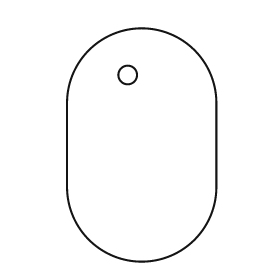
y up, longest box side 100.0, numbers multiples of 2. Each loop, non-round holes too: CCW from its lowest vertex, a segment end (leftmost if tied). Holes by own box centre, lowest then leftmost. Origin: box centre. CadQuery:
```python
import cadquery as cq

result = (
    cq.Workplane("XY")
    .moveTo(-32.0, -18.0)
    .threePointArc((0.0, -50.0), (32.0, -18.0))
    .lineTo(32.0, 18.0)
    .threePointArc((0.0, 50.0), (-32.0, 18.0))
    .close()
    .moveTo(-6.0, 30.0)
    .circle(4.0)
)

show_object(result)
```